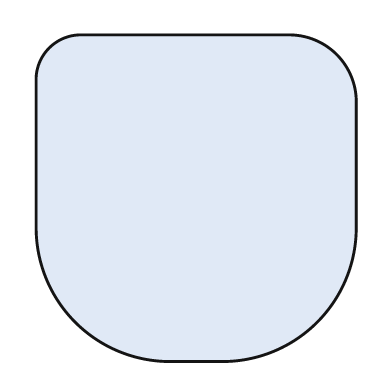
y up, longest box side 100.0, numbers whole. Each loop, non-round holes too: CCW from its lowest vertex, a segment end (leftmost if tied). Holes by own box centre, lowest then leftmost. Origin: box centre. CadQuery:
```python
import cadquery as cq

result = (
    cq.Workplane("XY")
    .moveTo(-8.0, -50.0)
    .lineTo(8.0, -50.0)
    .threePointArc((37.0, -38.0), (49.0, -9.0))
    .lineTo(49.0, 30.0)
    .threePointArc((43.0, 44.0), (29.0, 50.0))
    .lineTo(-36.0, 50.0)
    .threePointArc((-45.0, 46.0), (-49.0, 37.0))
    .lineTo(-49.0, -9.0)
    .threePointArc((-37.0, -38.0), (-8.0, -50.0))
    .close()
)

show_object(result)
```